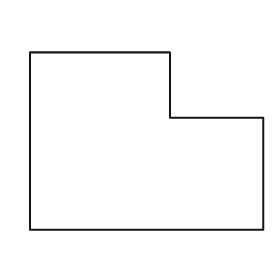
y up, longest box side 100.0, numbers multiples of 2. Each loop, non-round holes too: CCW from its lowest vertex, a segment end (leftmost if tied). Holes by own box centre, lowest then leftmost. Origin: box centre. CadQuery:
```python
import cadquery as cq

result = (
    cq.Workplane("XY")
    .moveTo(-50.0, -38.0)
    .lineTo(50.0, -38.0)
    .lineTo(50.0, 10.0)
    .lineTo(10.0, 10.0)
    .lineTo(10.0, 38.0)
    .lineTo(-50.0, 38.0)
    .close()
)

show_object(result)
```